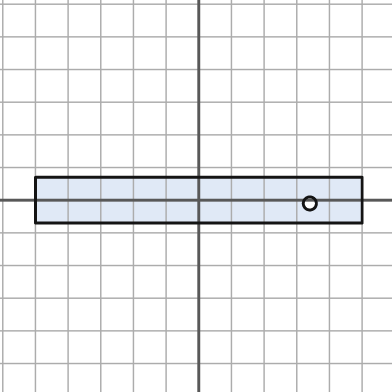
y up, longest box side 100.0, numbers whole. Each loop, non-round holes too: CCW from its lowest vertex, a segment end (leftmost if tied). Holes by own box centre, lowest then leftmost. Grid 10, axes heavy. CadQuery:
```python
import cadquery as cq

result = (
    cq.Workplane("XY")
    .moveTo(-50.0, -7.0)
    .lineTo(50.0, -7.0)
    .lineTo(50.0, 7.0)
    .lineTo(-50.0, 7.0)
    .close()
    .moveTo(34.0, -1.0)
    .circle(2.0)
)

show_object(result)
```